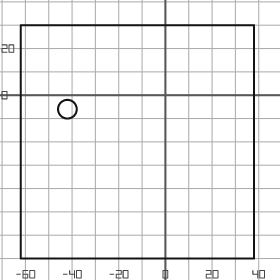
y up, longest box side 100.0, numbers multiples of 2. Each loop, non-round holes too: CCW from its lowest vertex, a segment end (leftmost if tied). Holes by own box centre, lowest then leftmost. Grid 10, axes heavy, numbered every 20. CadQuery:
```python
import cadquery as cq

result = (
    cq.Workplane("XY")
    .moveTo(-62.0, -70.0)
    .lineTo(38.0, -70.0)
    .lineTo(38.0, 30.0)
    .lineTo(-62.0, 30.0)
    .close()
    .moveTo(-42.0, -6.0)
    .circle(4.0)
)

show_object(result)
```